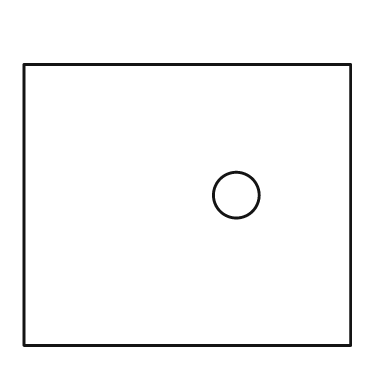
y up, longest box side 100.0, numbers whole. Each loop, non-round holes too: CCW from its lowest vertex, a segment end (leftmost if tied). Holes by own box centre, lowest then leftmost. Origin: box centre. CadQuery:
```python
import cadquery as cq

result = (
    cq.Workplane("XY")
    .moveTo(-50.0, -43.0)
    .lineTo(50.0, -43.0)
    .lineTo(50.0, 43.0)
    .lineTo(-50.0, 43.0)
    .close()
    .moveTo(15.0, 3.0)
    .circle(7.0)
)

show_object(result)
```